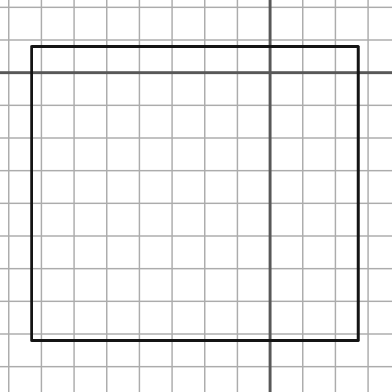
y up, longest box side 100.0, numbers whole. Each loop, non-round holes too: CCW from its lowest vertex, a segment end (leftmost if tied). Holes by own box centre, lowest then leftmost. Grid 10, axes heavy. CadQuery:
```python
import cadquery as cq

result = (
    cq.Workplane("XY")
    .moveTo(-73.0, -82.0)
    .lineTo(27.0, -82.0)
    .lineTo(27.0, 8.0)
    .lineTo(-73.0, 8.0)
    .close()
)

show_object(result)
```